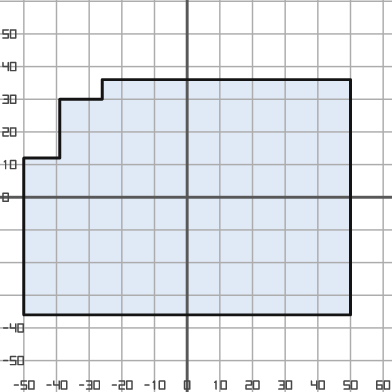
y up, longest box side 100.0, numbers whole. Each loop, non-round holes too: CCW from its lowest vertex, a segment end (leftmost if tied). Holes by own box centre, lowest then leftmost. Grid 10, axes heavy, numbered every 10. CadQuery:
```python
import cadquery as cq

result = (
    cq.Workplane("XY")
    .moveTo(-50.0, -36.0)
    .lineTo(50.0, -36.0)
    .lineTo(50.0, 36.0)
    .lineTo(-26.0, 36.0)
    .lineTo(-26.0, 30.0)
    .lineTo(-39.0, 30.0)
    .lineTo(-39.0, 12.0)
    .lineTo(-50.0, 12.0)
    .close()
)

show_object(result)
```